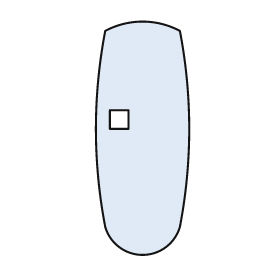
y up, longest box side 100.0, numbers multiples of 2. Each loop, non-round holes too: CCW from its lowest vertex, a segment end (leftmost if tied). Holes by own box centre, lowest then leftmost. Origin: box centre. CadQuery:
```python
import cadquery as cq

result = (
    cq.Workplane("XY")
    .moveTo(-16.0, -38.0)
    .threePointArc((0.0, -50.0), (16.0, -38.0))
    .threePointArc((20.0, 4.0), (16.0, 46.0))
    .threePointArc((0.0, 50.0), (-16.0, 46.0))
    .threePointArc((-20.0, 4.0), (-16.0, -38.0))
    .close()
    .moveTo(-14.0, 4.0)
    .lineTo(-6.0, 4.0)
    .lineTo(-6.0, 12.0)
    .lineTo(-14.0, 12.0)
    .close()
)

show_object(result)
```